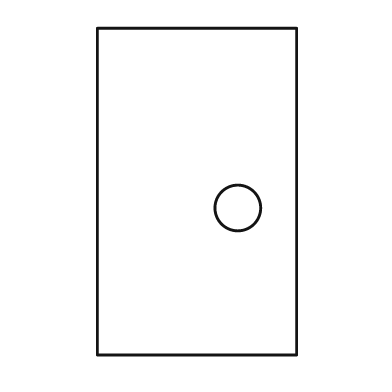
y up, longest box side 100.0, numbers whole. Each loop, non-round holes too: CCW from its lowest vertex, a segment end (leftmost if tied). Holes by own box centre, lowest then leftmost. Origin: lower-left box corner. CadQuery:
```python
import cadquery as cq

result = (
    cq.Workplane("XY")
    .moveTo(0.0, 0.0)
    .lineTo(61.0, 0.0)
    .lineTo(61.0, 100.0)
    .lineTo(0.0, 100.0)
    .close()
    .moveTo(43.0, 45.0)
    .circle(7.0)
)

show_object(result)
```